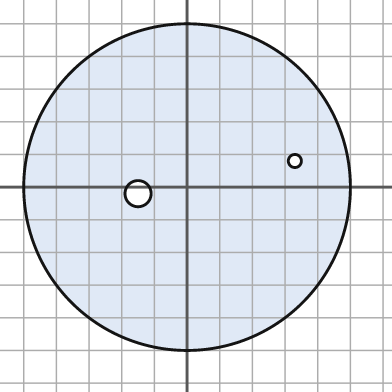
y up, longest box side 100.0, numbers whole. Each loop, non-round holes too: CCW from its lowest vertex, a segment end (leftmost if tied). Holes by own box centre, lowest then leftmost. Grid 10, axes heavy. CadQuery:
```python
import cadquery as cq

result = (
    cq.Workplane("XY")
    .moveTo(0.0, 0.0)
    .circle(50.0)
    .moveTo(-15.0, -2.0)
    .circle(4.0)
    .moveTo(33.0, 8.0)
    .circle(2.0)
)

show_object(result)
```